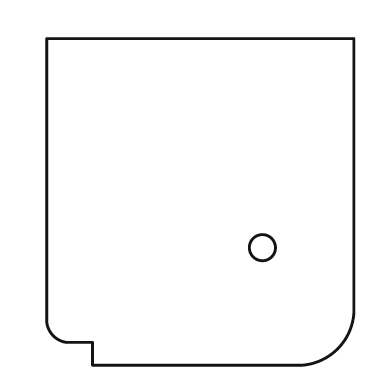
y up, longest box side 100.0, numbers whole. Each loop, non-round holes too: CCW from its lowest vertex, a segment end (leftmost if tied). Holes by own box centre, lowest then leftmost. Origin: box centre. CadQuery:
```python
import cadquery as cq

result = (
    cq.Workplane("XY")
    .moveTo(-33.0, -50.0)
    .lineTo(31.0, -50.0)
    .threePointArc((42.0, -45.0), (47.0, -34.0))
    .lineTo(47.0, 50.0)
    .lineTo(-47.0, 50.0)
    .lineTo(-47.0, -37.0)
    .threePointArc((-45.0, -41.0), (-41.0, -43.0))
    .lineTo(-33.0, -43.0)
    .close()
    .moveTo(19.0, -14.0)
    .circle(4.0)
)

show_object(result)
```